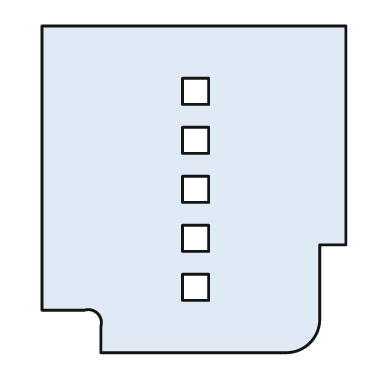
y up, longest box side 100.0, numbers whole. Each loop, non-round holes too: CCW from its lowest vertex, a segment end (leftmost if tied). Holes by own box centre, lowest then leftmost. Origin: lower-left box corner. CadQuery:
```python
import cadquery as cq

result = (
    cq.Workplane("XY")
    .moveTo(18.0, 0.0)
    .lineTo(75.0, 0.0)
    .threePointArc((82.0, 3.0), (85.0, 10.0))
    .lineTo(85.0, 33.0)
    .lineTo(93.0, 33.0)
    .lineTo(93.0, 100.0)
    .lineTo(0.0, 100.0)
    .lineTo(0.0, 13.0)
    .lineTo(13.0, 13.0)
    .threePointArc((17.0, 12.0), (18.0, 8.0))
    .close()
    .moveTo(43.0, 16.0)
    .lineTo(51.0, 16.0)
    .lineTo(51.0, 24.0)
    .lineTo(43.0, 24.0)
    .close()
    .moveTo(43.0, 31.0)
    .lineTo(51.0, 31.0)
    .lineTo(51.0, 39.0)
    .lineTo(43.0, 39.0)
    .close()
    .moveTo(43.0, 46.0)
    .lineTo(51.0, 46.0)
    .lineTo(51.0, 54.0)
    .lineTo(43.0, 54.0)
    .close()
    .moveTo(43.0, 61.0)
    .lineTo(51.0, 61.0)
    .lineTo(51.0, 69.0)
    .lineTo(43.0, 69.0)
    .close()
    .moveTo(43.0, 76.0)
    .lineTo(51.0, 76.0)
    .lineTo(51.0, 84.0)
    .lineTo(43.0, 84.0)
    .close()
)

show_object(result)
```